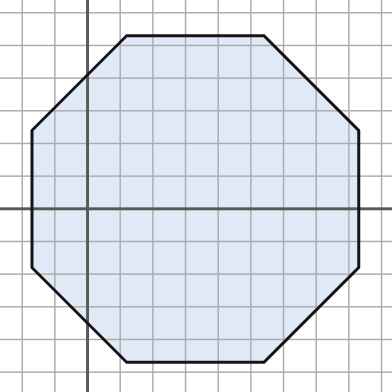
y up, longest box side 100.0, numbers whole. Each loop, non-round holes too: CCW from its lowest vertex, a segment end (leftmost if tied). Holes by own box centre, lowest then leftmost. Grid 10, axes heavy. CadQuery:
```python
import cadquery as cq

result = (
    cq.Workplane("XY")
    .moveTo(12.0, -47.0)
    .lineTo(54.0, -47.0)
    .lineTo(83.0, -18.0)
    .lineTo(83.0, 24.0)
    .lineTo(54.0, 53.0)
    .lineTo(12.0, 53.0)
    .lineTo(-17.0, 24.0)
    .lineTo(-17.0, -18.0)
    .close()
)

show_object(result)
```